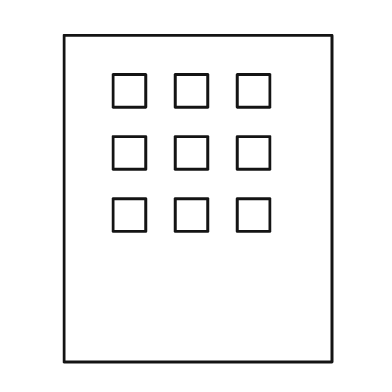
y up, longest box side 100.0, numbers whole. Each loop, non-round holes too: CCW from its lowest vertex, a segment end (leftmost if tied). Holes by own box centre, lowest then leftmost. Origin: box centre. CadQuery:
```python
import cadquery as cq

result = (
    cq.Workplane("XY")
    .moveTo(-41.0, -50.0)
    .lineTo(41.0, -50.0)
    .lineTo(41.0, 50.0)
    .lineTo(-41.0, 50.0)
    .close()
    .moveTo(-26.0, -10.0)
    .lineTo(-16.0, -10.0)
    .lineTo(-16.0, 0.0)
    .lineTo(-26.0, 0.0)
    .close()
    .moveTo(-7.0, -10.0)
    .lineTo(3.0, -10.0)
    .lineTo(3.0, 0.0)
    .lineTo(-7.0, 0.0)
    .close()
    .moveTo(12.0, -10.0)
    .lineTo(22.0, -10.0)
    .lineTo(22.0, 0.0)
    .lineTo(12.0, 0.0)
    .close()
    .moveTo(-26.0, 9.0)
    .lineTo(-16.0, 9.0)
    .lineTo(-16.0, 19.0)
    .lineTo(-26.0, 19.0)
    .close()
    .moveTo(-7.0, 9.0)
    .lineTo(3.0, 9.0)
    .lineTo(3.0, 19.0)
    .lineTo(-7.0, 19.0)
    .close()
    .moveTo(12.0, 9.0)
    .lineTo(22.0, 9.0)
    .lineTo(22.0, 19.0)
    .lineTo(12.0, 19.0)
    .close()
    .moveTo(-26.0, 28.0)
    .lineTo(-16.0, 28.0)
    .lineTo(-16.0, 38.0)
    .lineTo(-26.0, 38.0)
    .close()
    .moveTo(-7.0, 28.0)
    .lineTo(3.0, 28.0)
    .lineTo(3.0, 38.0)
    .lineTo(-7.0, 38.0)
    .close()
    .moveTo(12.0, 28.0)
    .lineTo(22.0, 28.0)
    .lineTo(22.0, 38.0)
    .lineTo(12.0, 38.0)
    .close()
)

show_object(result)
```